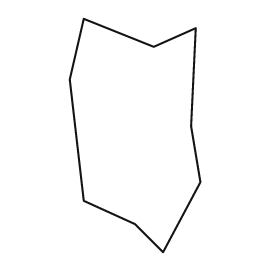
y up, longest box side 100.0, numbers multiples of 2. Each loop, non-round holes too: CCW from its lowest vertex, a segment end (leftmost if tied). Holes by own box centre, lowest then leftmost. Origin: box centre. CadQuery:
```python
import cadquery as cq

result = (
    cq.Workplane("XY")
    .moveTo(12.0, -50.0)
    .lineTo(28.0, -20.0)
    .lineTo(24.0, 4.0)
    .lineTo(26.0, 46.0)
    .lineTo(8.0, 38.0)
    .lineTo(-22.0, 50.0)
    .lineTo(-28.0, 24.0)
    .lineTo(-22.0, -28.0)
    .lineTo(0.0, -38.0)
    .close()
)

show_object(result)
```